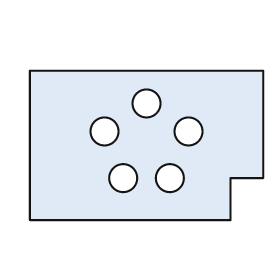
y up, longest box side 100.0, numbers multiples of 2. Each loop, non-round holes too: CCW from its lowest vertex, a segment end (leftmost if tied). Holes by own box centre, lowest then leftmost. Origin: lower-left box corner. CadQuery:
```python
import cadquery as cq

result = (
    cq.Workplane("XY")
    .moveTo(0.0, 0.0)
    .lineTo(86.0, 0.0)
    .lineTo(86.0, 18.0)
    .lineTo(100.0, 18.0)
    .lineTo(100.0, 64.0)
    .lineTo(0.0, 64.0)
    .close()
    .moveTo(40.0, 18.0)
    .circle(6.0)
    .moveTo(60.0, 18.0)
    .circle(6.0)
    .moveTo(32.0, 38.0)
    .circle(6.0)
    .moveTo(68.0, 38.0)
    .circle(6.0)
    .moveTo(50.0, 50.0)
    .circle(6.0)
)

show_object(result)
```